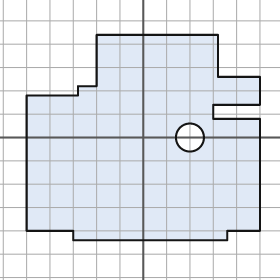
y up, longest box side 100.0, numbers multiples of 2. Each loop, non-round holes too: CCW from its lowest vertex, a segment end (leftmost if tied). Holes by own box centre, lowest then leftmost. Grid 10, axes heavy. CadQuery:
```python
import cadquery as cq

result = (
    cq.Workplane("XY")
    .moveTo(-30.0, -44.0)
    .lineTo(36.0, -44.0)
    .lineTo(36.0, -40.0)
    .lineTo(50.0, -40.0)
    .lineTo(50.0, 8.0)
    .lineTo(30.0, 8.0)
    .lineTo(30.0, 14.0)
    .lineTo(50.0, 14.0)
    .lineTo(50.0, 26.0)
    .lineTo(32.0, 26.0)
    .lineTo(32.0, 44.0)
    .lineTo(-20.0, 44.0)
    .lineTo(-20.0, 22.0)
    .lineTo(-28.0, 22.0)
    .lineTo(-28.0, 18.0)
    .lineTo(-50.0, 18.0)
    .lineTo(-50.0, -40.0)
    .lineTo(-30.0, -40.0)
    .close()
    .moveTo(20.0, 0.0)
    .circle(6.0)
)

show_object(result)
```